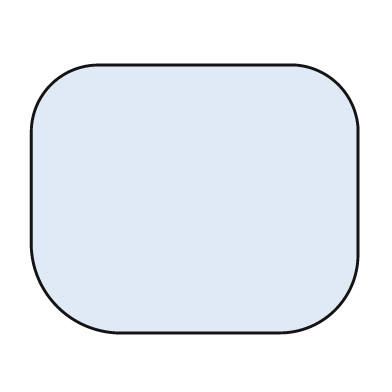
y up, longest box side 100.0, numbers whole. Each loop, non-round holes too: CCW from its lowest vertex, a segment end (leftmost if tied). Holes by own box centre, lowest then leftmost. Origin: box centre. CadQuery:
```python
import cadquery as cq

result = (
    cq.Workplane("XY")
    .moveTo(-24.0, -41.0)
    .lineTo(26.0, -41.0)
    .threePointArc((43.0, -34.0), (50.0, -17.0))
    .lineTo(50.0, 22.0)
    .threePointArc((44.0, 35.0), (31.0, 41.0))
    .lineTo(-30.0, 41.0)
    .threePointArc((-44.0, 35.0), (-50.0, 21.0))
    .lineTo(-50.0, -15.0)
    .threePointArc((-42.0, -33.0), (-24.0, -41.0))
    .close()
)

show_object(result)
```